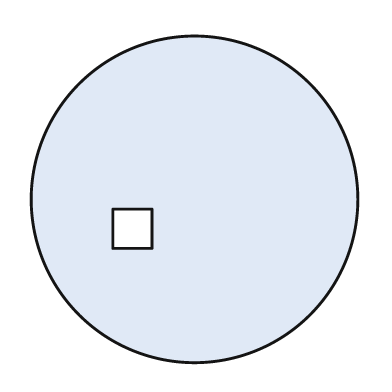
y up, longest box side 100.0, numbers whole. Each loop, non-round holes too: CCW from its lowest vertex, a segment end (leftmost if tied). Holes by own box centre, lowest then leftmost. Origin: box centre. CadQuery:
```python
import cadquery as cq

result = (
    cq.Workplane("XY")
    .moveTo(0.0, 0.0)
    .circle(50.0)
    .moveTo(-25.0, -15.0)
    .lineTo(-13.0, -15.0)
    .lineTo(-13.0, -3.0)
    .lineTo(-25.0, -3.0)
    .close()
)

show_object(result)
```